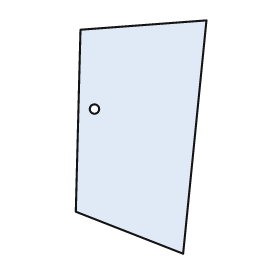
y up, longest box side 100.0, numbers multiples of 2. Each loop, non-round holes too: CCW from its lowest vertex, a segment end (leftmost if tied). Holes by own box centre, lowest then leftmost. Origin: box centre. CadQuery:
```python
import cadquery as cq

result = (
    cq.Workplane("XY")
    .moveTo(18.0, -50.0)
    .lineTo(28.0, 50.0)
    .lineTo(-26.0, 46.0)
    .lineTo(-28.0, -32.0)
    .close()
    .moveTo(-20.0, 12.0)
    .circle(2.0)
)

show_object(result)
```